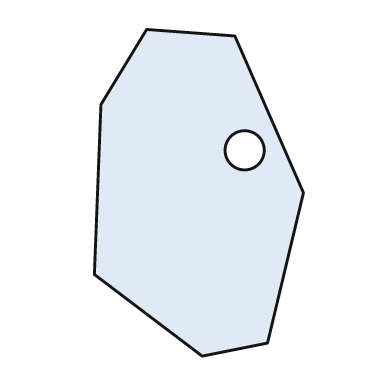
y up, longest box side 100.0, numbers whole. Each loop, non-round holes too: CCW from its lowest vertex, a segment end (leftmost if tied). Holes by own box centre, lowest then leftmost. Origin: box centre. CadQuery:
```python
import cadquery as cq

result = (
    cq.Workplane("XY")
    .moveTo(1.0, -50.0)
    .lineTo(21.0, -46.0)
    .lineTo(32.0, 0.0)
    .lineTo(11.0, 48.0)
    .lineTo(-16.0, 50.0)
    .lineTo(-30.0, 27.0)
    .lineTo(-32.0, -25.0)
    .close()
    .moveTo(14.0, 13.0)
    .circle(6.0)
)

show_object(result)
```